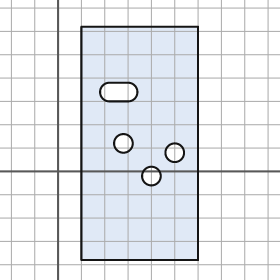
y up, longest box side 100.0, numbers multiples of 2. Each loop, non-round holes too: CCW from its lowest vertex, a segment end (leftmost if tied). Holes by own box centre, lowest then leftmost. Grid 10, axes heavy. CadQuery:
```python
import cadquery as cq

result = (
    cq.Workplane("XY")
    .moveTo(10.0, -38.0)
    .lineTo(60.0, -38.0)
    .lineTo(60.0, 62.0)
    .lineTo(10.0, 62.0)
    .close()
    .moveTo(40.0, -2.0)
    .circle(4.0)
    .moveTo(50.0, 8.0)
    .circle(4.0)
    .moveTo(28.0, 12.0)
    .circle(4.0)
    .moveTo(22.0, 30.0)
    .lineTo(30.0, 30.0)
    .threePointArc((34.0, 34.0), (30.0, 38.0))
    .lineTo(22.0, 38.0)
    .threePointArc((18.0, 34.0), (22.0, 30.0))
    .close()
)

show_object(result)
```